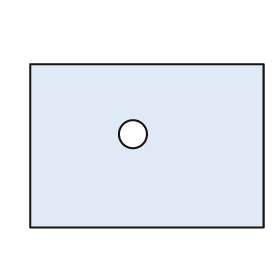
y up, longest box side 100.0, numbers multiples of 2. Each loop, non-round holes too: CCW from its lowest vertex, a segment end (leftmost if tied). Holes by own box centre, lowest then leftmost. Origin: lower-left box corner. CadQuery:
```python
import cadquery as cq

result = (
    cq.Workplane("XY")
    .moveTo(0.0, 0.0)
    .lineTo(100.0, 0.0)
    .lineTo(100.0, 70.0)
    .lineTo(0.0, 70.0)
    .close()
    .moveTo(44.0, 40.0)
    .circle(6.0)
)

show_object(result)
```